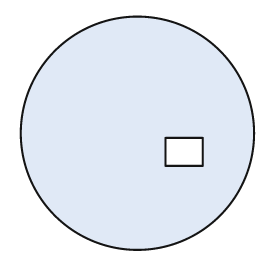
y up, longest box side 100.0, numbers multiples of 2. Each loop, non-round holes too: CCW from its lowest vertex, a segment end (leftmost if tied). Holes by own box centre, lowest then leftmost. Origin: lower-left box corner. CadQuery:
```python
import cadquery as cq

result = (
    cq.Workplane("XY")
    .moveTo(50.0, 50.0)
    .circle(50.0)
    .moveTo(62.0, 36.0)
    .lineTo(78.0, 36.0)
    .lineTo(78.0, 48.0)
    .lineTo(62.0, 48.0)
    .close()
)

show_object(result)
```